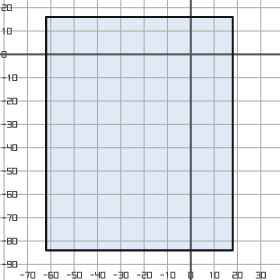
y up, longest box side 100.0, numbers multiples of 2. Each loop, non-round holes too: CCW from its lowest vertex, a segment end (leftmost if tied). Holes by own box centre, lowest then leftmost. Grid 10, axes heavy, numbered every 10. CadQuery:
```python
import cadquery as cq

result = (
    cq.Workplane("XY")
    .moveTo(-62.0, -84.0)
    .lineTo(18.0, -84.0)
    .lineTo(18.0, 16.0)
    .lineTo(-62.0, 16.0)
    .close()
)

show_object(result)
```